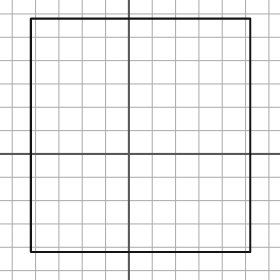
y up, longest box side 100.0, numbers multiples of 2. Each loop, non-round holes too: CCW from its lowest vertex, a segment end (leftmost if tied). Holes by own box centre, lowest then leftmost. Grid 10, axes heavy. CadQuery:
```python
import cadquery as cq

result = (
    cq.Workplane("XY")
    .moveTo(-42.0, -42.0)
    .lineTo(52.0, -42.0)
    .lineTo(52.0, 58.0)
    .lineTo(-42.0, 58.0)
    .close()
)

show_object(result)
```